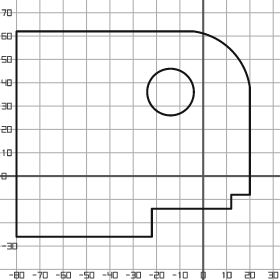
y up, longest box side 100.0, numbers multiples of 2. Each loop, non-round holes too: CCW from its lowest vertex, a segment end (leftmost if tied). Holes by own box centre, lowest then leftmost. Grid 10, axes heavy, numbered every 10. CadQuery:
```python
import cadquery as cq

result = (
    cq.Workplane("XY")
    .moveTo(-80.0, -26.0)
    .lineTo(-22.0, -26.0)
    .lineTo(-22.0, -14.0)
    .lineTo(12.0, -14.0)
    .lineTo(12.0, -8.0)
    .lineTo(20.0, -8.0)
    .lineTo(20.0, 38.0)
    .threePointArc((12.0, 54.0), (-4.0, 62.0))
    .lineTo(-80.0, 62.0)
    .close()
    .moveTo(-14.0, 36.0)
    .circle(10.0)
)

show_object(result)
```